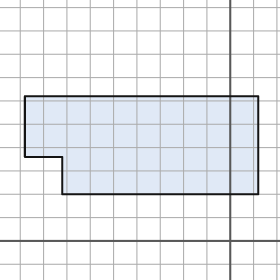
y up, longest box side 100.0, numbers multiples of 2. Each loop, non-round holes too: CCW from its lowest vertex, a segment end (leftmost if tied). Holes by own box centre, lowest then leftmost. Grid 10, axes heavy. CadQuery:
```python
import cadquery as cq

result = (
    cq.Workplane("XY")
    .moveTo(-72.0, 20.0)
    .lineTo(12.0, 20.0)
    .lineTo(12.0, 62.0)
    .lineTo(-88.0, 62.0)
    .lineTo(-88.0, 36.0)
    .lineTo(-72.0, 36.0)
    .close()
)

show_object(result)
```